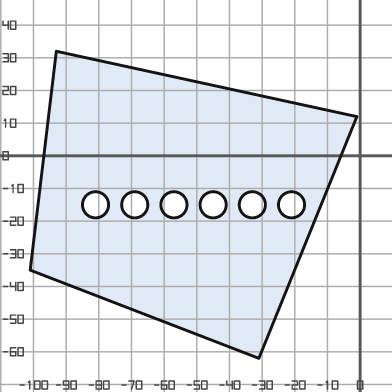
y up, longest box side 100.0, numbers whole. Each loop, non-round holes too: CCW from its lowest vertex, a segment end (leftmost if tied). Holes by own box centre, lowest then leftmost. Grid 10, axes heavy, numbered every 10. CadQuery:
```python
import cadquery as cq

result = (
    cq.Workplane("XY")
    .moveTo(-31.0, -62.0)
    .lineTo(-1.0, 12.0)
    .lineTo(-93.0, 32.0)
    .lineTo(-101.0, -35.0)
    .close()
    .moveTo(-81.0, -15.0)
    .circle(4.0)
    .moveTo(-69.0, -15.0)
    .circle(4.0)
    .moveTo(-57.0, -15.0)
    .circle(4.0)
    .moveTo(-45.0, -15.0)
    .circle(4.0)
    .moveTo(-33.0, -15.0)
    .circle(4.0)
    .moveTo(-21.0, -15.0)
    .circle(4.0)
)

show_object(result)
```